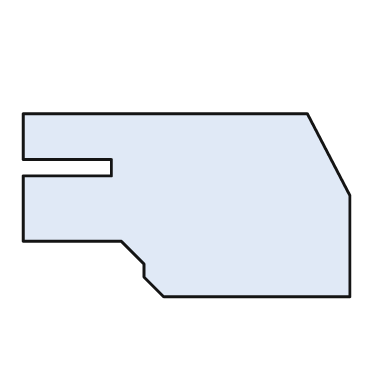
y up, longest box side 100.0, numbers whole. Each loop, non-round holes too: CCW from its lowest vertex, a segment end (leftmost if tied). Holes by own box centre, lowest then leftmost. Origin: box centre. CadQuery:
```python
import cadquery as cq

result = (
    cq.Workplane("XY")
    .moveTo(-7.0, -28.0)
    .lineTo(50.0, -28.0)
    .lineTo(50.0, 3.0)
    .lineTo(37.0, 28.0)
    .lineTo(-50.0, 28.0)
    .lineTo(-50.0, 14.0)
    .lineTo(-23.0, 14.0)
    .lineTo(-23.0, 9.0)
    .lineTo(-50.0, 9.0)
    .lineTo(-50.0, -11.0)
    .lineTo(-20.0, -11.0)
    .lineTo(-13.0, -18.0)
    .lineTo(-13.0, -22.0)
    .close()
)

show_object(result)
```